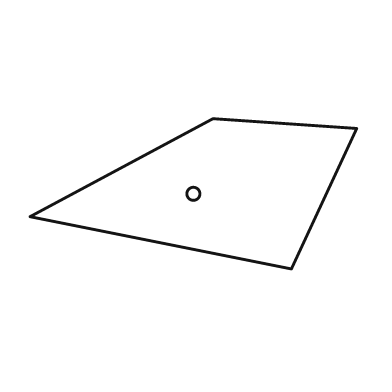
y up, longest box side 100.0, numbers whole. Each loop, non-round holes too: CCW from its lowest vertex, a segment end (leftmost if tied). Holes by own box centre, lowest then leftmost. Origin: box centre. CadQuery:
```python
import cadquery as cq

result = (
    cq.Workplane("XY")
    .moveTo(30.0, -23.0)
    .lineTo(50.0, 20.0)
    .lineTo(6.0, 23.0)
    .lineTo(-50.0, -7.0)
    .close()
    .moveTo(0.0, 0.0)
    .circle(2.0)
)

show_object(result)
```